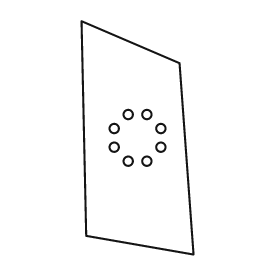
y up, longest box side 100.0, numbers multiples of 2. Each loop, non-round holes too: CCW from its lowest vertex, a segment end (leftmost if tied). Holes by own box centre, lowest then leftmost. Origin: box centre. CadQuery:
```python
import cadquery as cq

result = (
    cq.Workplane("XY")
    .moveTo(24.0, -50.0)
    .lineTo(18.0, 32.0)
    .lineTo(-24.0, 50.0)
    .lineTo(-22.0, -42.0)
    .close()
    .moveTo(-4.0, -10.0)
    .circle(2.0)
    .moveTo(4.0, -10.0)
    .circle(2.0)
    .moveTo(-10.0, -4.0)
    .circle(2.0)
    .moveTo(10.0, -4.0)
    .circle(2.0)
    .moveTo(-10.0, 4.0)
    .circle(2.0)
    .moveTo(10.0, 4.0)
    .circle(2.0)
    .moveTo(-4.0, 10.0)
    .circle(2.0)
    .moveTo(4.0, 10.0)
    .circle(2.0)
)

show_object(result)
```